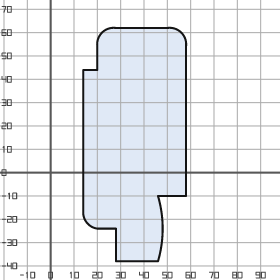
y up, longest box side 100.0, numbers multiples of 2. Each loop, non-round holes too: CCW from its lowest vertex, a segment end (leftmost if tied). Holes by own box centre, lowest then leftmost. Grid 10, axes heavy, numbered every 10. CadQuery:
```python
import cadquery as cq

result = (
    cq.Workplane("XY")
    .moveTo(28.0, -38.0)
    .lineTo(46.0, -38.0)
    .threePointArc((48.0, -24.0), (46.0, -10.0))
    .lineTo(58.0, -10.0)
    .lineTo(58.0, 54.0)
    .threePointArc((56.0, 60.0), (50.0, 62.0))
    .lineTo(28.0, 62.0)
    .threePointArc((22.0, 60.0), (20.0, 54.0))
    .lineTo(20.0, 44.0)
    .lineTo(14.0, 44.0)
    .lineTo(14.0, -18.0)
    .threePointArc((16.0, -22.0), (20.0, -24.0))
    .lineTo(28.0, -24.0)
    .close()
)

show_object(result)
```